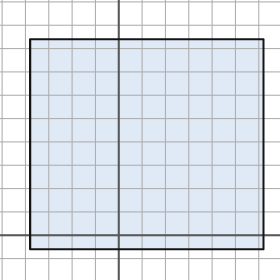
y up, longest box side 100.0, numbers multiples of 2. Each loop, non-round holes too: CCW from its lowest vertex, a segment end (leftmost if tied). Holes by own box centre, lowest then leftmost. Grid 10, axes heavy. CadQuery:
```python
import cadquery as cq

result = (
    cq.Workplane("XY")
    .moveTo(-38.0, -6.0)
    .lineTo(62.0, -6.0)
    .lineTo(62.0, 84.0)
    .lineTo(-38.0, 84.0)
    .close()
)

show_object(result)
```